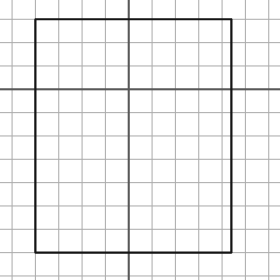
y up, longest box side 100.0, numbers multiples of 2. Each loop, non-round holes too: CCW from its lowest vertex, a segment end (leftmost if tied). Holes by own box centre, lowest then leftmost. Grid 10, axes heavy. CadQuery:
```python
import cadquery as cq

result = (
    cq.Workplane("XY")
    .moveTo(-40.0, -70.0)
    .lineTo(44.0, -70.0)
    .lineTo(44.0, 30.0)
    .lineTo(-40.0, 30.0)
    .close()
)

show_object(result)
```